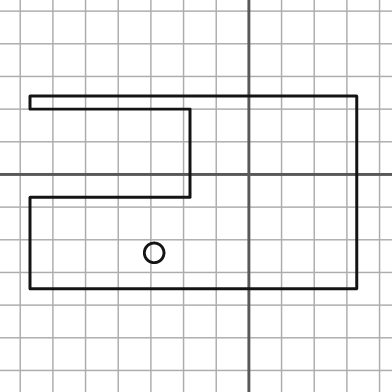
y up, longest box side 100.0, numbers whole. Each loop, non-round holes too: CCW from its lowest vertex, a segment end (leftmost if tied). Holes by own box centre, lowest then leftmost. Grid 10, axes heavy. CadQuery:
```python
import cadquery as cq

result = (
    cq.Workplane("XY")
    .moveTo(-67.0, -35.0)
    .lineTo(33.0, -35.0)
    .lineTo(33.0, 24.0)
    .lineTo(-67.0, 24.0)
    .lineTo(-67.0, 20.0)
    .lineTo(-18.0, 20.0)
    .lineTo(-18.0, -7.0)
    .lineTo(-67.0, -7.0)
    .close()
    .moveTo(-29.0, -24.0)
    .circle(3.0)
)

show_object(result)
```